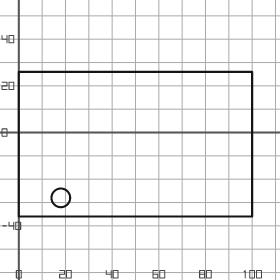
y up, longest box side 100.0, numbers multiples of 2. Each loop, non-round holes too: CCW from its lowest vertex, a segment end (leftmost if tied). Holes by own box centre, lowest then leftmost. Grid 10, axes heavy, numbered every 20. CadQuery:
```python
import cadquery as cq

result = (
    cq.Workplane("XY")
    .moveTo(0.0, -36.0)
    .lineTo(100.0, -36.0)
    .lineTo(100.0, 26.0)
    .lineTo(0.0, 26.0)
    .close()
    .moveTo(18.0, -28.0)
    .circle(4.0)
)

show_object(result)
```